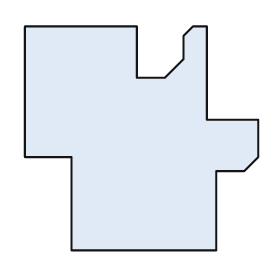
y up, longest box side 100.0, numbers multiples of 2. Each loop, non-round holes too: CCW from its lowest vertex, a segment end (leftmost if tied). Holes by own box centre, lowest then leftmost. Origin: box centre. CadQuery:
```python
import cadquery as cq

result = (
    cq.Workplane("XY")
    .moveTo(-30.0, -48.0)
    .lineTo(32.0, -48.0)
    .lineTo(32.0, -14.0)
    .lineTo(44.0, -14.0)
    .lineTo(50.0, -8.0)
    .lineTo(50.0, 8.0)
    .lineTo(28.0, 8.0)
    .lineTo(28.0, 48.0)
    .lineTo(22.0, 48.0)
    .lineTo(18.0, 44.0)
    .lineTo(18.0, 34.0)
    .lineTo(10.0, 26.0)
    .lineTo(-2.0, 26.0)
    .lineTo(-2.0, 48.0)
    .lineTo(-50.0, 48.0)
    .lineTo(-50.0, -8.0)
    .lineTo(-30.0, -8.0)
    .close()
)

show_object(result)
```